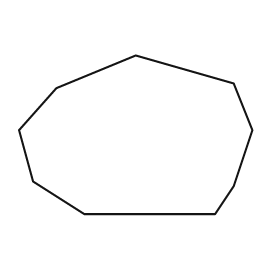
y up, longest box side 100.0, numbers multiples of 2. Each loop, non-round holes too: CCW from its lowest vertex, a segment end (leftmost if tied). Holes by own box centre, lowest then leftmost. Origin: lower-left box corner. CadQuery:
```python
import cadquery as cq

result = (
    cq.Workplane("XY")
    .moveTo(28.0, 0.0)
    .lineTo(84.0, 0.0)
    .lineTo(92.0, 12.0)
    .lineTo(100.0, 36.0)
    .lineTo(92.0, 56.0)
    .lineTo(50.0, 68.0)
    .lineTo(16.0, 54.0)
    .lineTo(0.0, 36.0)
    .lineTo(6.0, 14.0)
    .close()
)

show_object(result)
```